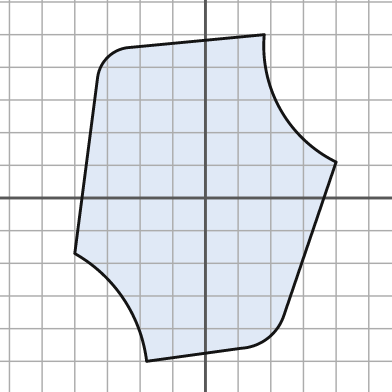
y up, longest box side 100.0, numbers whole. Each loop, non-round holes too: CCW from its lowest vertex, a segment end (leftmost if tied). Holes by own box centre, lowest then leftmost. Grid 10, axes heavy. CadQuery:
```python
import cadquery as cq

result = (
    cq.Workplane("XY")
    .moveTo(-18.0, -50.0)
    .lineTo(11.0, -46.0)
    .threePointArc((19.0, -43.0), (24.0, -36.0))
    .lineTo(40.0, 11.0)
    .threePointArc((23.0, 27.0), (18.0, 50.0))
    .lineTo(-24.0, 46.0)
    .threePointArc((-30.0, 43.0), (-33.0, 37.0))
    .lineTo(-40.0, -17.0)
    .threePointArc((-25.0, -31.0), (-18.0, -50.0))
    .close()
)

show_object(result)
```